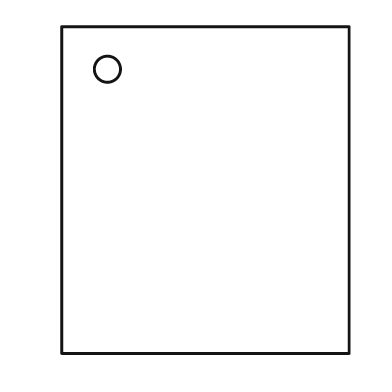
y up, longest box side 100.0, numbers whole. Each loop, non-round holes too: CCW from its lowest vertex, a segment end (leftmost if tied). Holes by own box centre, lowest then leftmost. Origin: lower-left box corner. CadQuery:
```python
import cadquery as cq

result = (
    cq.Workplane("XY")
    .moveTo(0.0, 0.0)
    .lineTo(88.0, 0.0)
    .lineTo(88.0, 100.0)
    .lineTo(0.0, 100.0)
    .close()
    .moveTo(14.0, 87.0)
    .circle(4.0)
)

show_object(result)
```